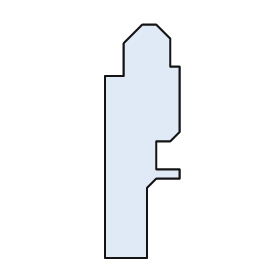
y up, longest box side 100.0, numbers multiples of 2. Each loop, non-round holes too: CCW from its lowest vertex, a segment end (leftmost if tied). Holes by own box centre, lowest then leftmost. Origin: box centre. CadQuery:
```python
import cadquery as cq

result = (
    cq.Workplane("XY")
    .moveTo(-16.0, -50.0)
    .lineTo(2.0, -50.0)
    .lineTo(2.0, -20.0)
    .lineTo(6.0, -16.0)
    .lineTo(16.0, -16.0)
    .lineTo(16.0, -12.0)
    .lineTo(6.0, -12.0)
    .lineTo(6.0, 0.0)
    .lineTo(12.0, 0.0)
    .lineTo(16.0, 4.0)
    .lineTo(16.0, 32.0)
    .lineTo(12.0, 32.0)
    .lineTo(12.0, 44.0)
    .lineTo(6.0, 50.0)
    .lineTo(0.0, 50.0)
    .lineTo(-8.0, 42.0)
    .lineTo(-8.0, 28.0)
    .lineTo(-16.0, 28.0)
    .close()
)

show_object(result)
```